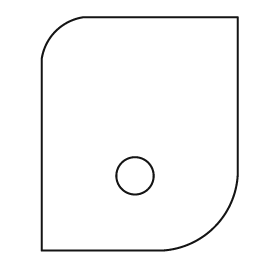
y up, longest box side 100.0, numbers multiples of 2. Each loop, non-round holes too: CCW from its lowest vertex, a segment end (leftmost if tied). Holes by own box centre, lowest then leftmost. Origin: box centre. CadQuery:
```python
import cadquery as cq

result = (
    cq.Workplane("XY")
    .moveTo(-42.0, -50.0)
    .lineTo(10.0, -50.0)
    .threePointArc((32.0, -40.0), (42.0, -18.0))
    .lineTo(42.0, 50.0)
    .lineTo(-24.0, 50.0)
    .threePointArc((-36.0, 44.0), (-42.0, 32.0))
    .close()
    .moveTo(-2.0, -18.0)
    .circle(8.0)
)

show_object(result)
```